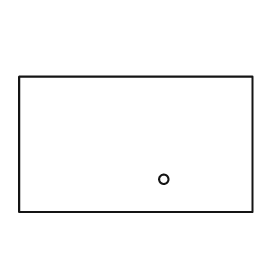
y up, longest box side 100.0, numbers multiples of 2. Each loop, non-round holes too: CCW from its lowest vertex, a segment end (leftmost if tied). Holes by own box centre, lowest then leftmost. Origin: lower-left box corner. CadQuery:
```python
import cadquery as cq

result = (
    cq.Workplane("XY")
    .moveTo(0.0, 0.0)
    .lineTo(100.0, 0.0)
    .lineTo(100.0, 58.0)
    .lineTo(0.0, 58.0)
    .close()
    .moveTo(62.0, 14.0)
    .circle(2.0)
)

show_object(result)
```